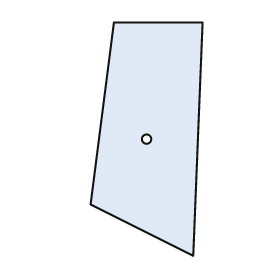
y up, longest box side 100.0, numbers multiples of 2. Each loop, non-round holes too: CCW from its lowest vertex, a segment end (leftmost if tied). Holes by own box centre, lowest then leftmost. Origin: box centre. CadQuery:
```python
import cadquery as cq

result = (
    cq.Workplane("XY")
    .moveTo(20.0, -50.0)
    .lineTo(24.0, 50.0)
    .lineTo(-14.0, 50.0)
    .lineTo(-24.0, -28.0)
    .close()
    .moveTo(0.0, 0.0)
    .circle(2.0)
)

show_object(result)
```